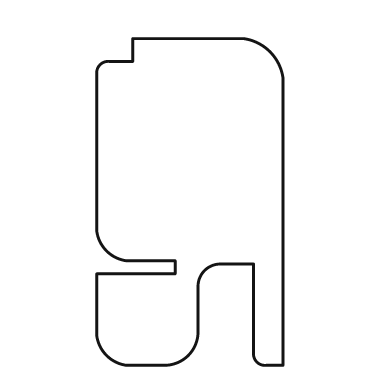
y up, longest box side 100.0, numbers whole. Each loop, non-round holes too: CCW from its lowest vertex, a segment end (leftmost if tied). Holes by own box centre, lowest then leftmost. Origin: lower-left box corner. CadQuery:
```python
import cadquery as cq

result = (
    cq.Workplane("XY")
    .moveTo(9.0, 0.0)
    .lineTo(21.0, 0.0)
    .threePointArc((28.0, 3.0), (31.0, 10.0))
    .lineTo(31.0, 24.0)
    .threePointArc((33.0, 29.0), (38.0, 31.0))
    .lineTo(48.0, 31.0)
    .lineTo(48.0, 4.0)
    .threePointArc((49.0, 1.0), (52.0, 0.0))
    .lineTo(57.0, 0.0)
    .lineTo(57.0, 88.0)
    .threePointArc((53.0, 96.0), (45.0, 100.0))
    .lineTo(11.0, 100.0)
    .lineTo(11.0, 93.0)
    .lineTo(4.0, 93.0)
    .threePointArc((1.0, 92.0), (0.0, 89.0))
    .lineTo(0.0, 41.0)
    .threePointArc((3.0, 35.0), (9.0, 32.0))
    .lineTo(24.0, 32.0)
    .lineTo(24.0, 28.0)
    .lineTo(0.0, 28.0)
    .lineTo(0.0, 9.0)
    .threePointArc((3.0, 3.0), (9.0, 0.0))
    .close()
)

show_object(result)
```